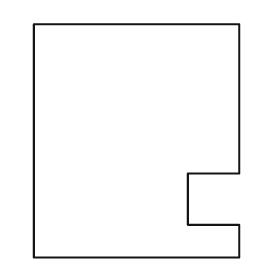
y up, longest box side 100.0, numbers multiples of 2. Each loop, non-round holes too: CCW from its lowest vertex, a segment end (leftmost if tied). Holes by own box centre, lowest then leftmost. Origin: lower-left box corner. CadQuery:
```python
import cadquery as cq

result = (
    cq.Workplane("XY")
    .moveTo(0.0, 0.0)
    .lineTo(88.0, 0.0)
    .lineTo(88.0, 14.0)
    .lineTo(66.0, 14.0)
    .lineTo(66.0, 36.0)
    .lineTo(88.0, 36.0)
    .lineTo(88.0, 100.0)
    .lineTo(0.0, 100.0)
    .close()
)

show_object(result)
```